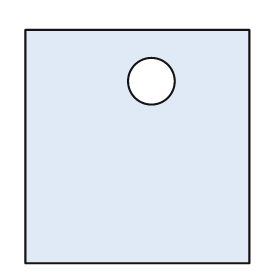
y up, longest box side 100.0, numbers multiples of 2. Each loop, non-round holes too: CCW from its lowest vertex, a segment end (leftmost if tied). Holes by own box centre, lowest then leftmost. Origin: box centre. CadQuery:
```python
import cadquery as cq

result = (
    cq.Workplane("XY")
    .moveTo(-48.0, -50.0)
    .lineTo(48.0, -50.0)
    .lineTo(48.0, 50.0)
    .lineTo(-48.0, 50.0)
    .close()
    .moveTo(6.0, 28.0)
    .circle(10.0)
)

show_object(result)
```